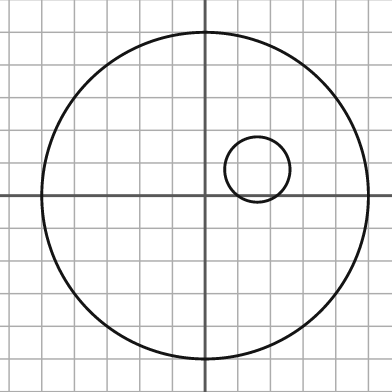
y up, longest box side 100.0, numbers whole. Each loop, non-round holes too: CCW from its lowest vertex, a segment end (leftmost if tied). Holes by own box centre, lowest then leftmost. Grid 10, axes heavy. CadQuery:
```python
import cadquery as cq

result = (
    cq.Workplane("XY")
    .moveTo(0.0, 0.0)
    .circle(50.0)
    .moveTo(16.0, 8.0)
    .circle(10.0)
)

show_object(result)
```